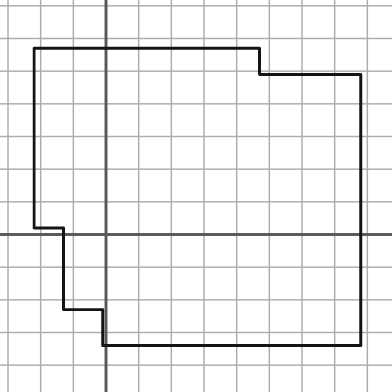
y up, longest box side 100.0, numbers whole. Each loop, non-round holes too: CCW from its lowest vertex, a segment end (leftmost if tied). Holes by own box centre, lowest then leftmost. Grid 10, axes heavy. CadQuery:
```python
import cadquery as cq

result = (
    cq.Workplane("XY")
    .moveTo(-1.0, -34.0)
    .lineTo(78.0, -34.0)
    .lineTo(78.0, 49.0)
    .lineTo(47.0, 49.0)
    .lineTo(47.0, 57.0)
    .lineTo(-22.0, 57.0)
    .lineTo(-22.0, 2.0)
    .lineTo(-13.0, 2.0)
    .lineTo(-13.0, -23.0)
    .lineTo(-1.0, -23.0)
    .close()
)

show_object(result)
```